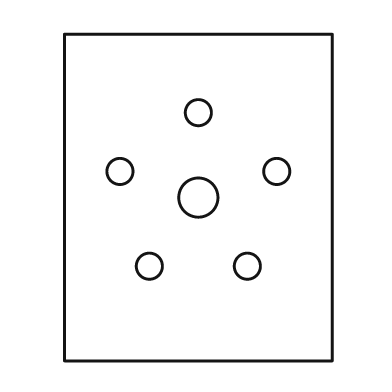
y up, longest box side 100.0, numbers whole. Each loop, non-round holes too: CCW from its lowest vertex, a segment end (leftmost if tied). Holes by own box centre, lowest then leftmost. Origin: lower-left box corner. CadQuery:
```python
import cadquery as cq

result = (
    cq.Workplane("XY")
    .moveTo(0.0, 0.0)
    .lineTo(82.0, 0.0)
    .lineTo(82.0, 100.0)
    .lineTo(0.0, 100.0)
    .close()
    .moveTo(26.0, 29.0)
    .circle(4.0)
    .moveTo(56.0, 29.0)
    .circle(4.0)
    .moveTo(41.0, 50.0)
    .circle(6.0)
    .moveTo(17.0, 58.0)
    .circle(4.0)
    .moveTo(65.0, 58.0)
    .circle(4.0)
    .moveTo(41.0, 76.0)
    .circle(4.0)
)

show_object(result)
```